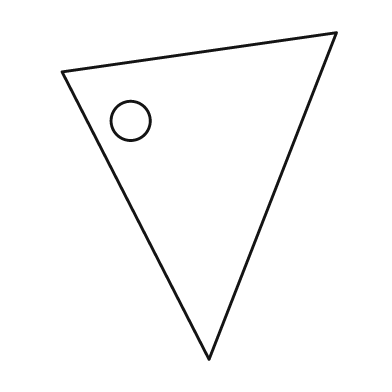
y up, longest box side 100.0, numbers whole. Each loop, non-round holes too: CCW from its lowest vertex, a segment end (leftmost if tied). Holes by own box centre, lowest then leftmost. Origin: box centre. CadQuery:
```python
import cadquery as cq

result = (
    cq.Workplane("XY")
    .moveTo(3.0, -50.0)
    .lineTo(42.0, 50.0)
    .lineTo(-42.0, 38.0)
    .close()
    .moveTo(-21.0, 23.0)
    .circle(6.0)
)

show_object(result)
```